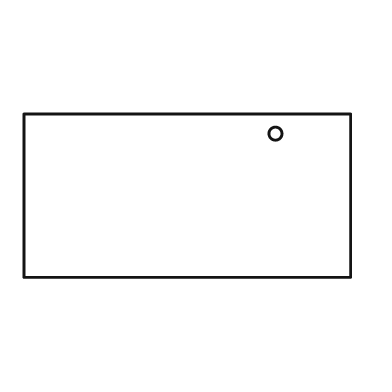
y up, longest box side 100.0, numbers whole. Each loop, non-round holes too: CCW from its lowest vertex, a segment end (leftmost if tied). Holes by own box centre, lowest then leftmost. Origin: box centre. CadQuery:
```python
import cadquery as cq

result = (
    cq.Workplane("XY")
    .moveTo(-50.0, -25.0)
    .lineTo(50.0, -25.0)
    .lineTo(50.0, 25.0)
    .lineTo(-50.0, 25.0)
    .close()
    .moveTo(27.0, 19.0)
    .circle(2.0)
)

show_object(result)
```